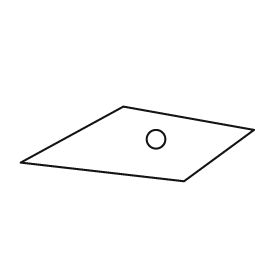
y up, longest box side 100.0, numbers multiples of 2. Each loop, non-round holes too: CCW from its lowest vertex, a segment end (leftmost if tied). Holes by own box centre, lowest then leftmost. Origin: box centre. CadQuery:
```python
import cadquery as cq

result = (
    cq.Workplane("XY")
    .moveTo(20.0, -16.0)
    .lineTo(50.0, 6.0)
    .lineTo(-6.0, 16.0)
    .lineTo(-50.0, -8.0)
    .close()
    .moveTo(8.0, 2.0)
    .circle(4.0)
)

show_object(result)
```